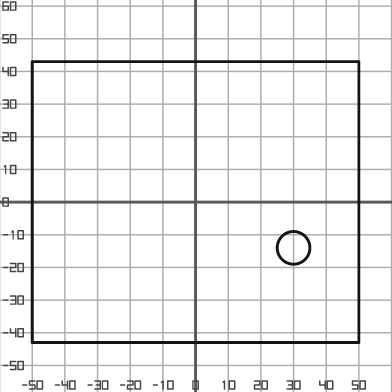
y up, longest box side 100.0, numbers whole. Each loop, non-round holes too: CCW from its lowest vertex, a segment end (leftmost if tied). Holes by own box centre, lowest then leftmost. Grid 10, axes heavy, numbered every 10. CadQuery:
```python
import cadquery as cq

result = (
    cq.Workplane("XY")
    .moveTo(-50.0, -43.0)
    .lineTo(50.0, -43.0)
    .lineTo(50.0, 43.0)
    .lineTo(-50.0, 43.0)
    .close()
    .moveTo(30.0, -14.0)
    .circle(5.0)
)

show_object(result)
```